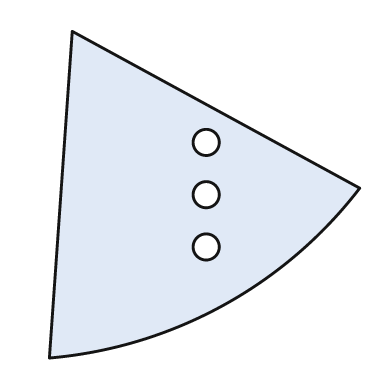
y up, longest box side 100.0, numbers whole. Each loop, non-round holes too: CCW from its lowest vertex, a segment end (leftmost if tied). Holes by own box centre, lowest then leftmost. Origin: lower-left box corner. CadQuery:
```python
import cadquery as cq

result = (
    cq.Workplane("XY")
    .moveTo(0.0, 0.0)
    .threePointArc((53.0, 16.0), (95.0, 52.0))
    .lineTo(7.0, 100.0)
    .close()
    .moveTo(48.0, 34.0)
    .circle(4.0)
    .moveTo(48.0, 50.0)
    .circle(4.0)
    .moveTo(48.0, 66.0)
    .circle(4.0)
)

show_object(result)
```